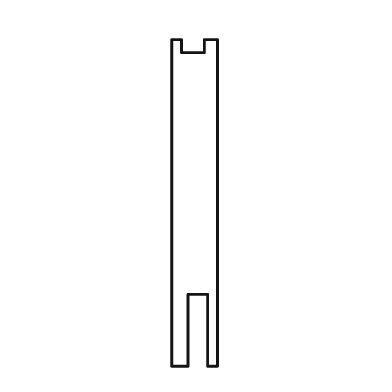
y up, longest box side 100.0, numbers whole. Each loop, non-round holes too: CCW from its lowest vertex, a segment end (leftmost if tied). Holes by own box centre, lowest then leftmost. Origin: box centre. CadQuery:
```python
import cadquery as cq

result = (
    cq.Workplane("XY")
    .moveTo(-7.0, -50.0)
    .lineTo(-2.0, -50.0)
    .lineTo(-2.0, -28.0)
    .lineTo(4.0, -28.0)
    .lineTo(4.0, -50.0)
    .lineTo(7.0, -50.0)
    .lineTo(7.0, 50.0)
    .lineTo(3.0, 50.0)
    .lineTo(3.0, 46.0)
    .lineTo(-4.0, 46.0)
    .lineTo(-4.0, 50.0)
    .lineTo(-7.0, 50.0)
    .close()
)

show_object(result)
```